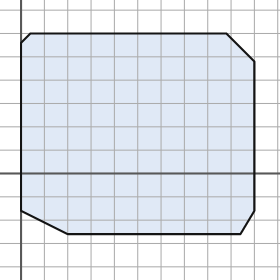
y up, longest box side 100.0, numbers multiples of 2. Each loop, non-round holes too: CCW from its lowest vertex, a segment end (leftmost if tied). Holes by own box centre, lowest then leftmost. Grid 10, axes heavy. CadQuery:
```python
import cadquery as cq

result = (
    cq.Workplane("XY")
    .moveTo(20.0, -26.0)
    .lineTo(94.0, -26.0)
    .lineTo(100.0, -16.0)
    .lineTo(100.0, 48.0)
    .lineTo(88.0, 60.0)
    .lineTo(4.0, 60.0)
    .lineTo(0.0, 56.0)
    .lineTo(0.0, -16.0)
    .close()
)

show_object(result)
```